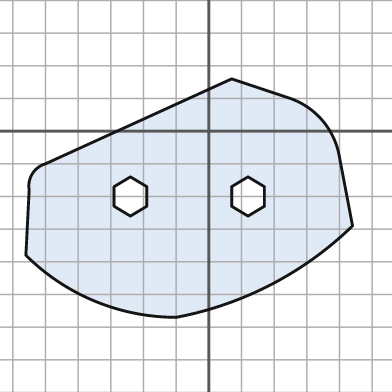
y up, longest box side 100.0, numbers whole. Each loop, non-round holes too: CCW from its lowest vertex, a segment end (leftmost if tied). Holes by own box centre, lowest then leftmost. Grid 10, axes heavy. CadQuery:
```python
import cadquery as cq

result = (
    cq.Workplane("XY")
    .moveTo(-10.0, -57.0)
    .threePointArc((19.0, -47.0), (44.0, -29.0))
    .lineTo(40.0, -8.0)
    .threePointArc((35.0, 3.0), (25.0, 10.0))
    .lineTo(7.0, 16.0)
    .lineTo(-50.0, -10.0)
    .threePointArc((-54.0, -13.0), (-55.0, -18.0))
    .lineTo(-56.0, -38.0)
    .threePointArc((-35.0, -52.0), (-10.0, -57.0))
    .close()
    .moveTo(-24.0, -26.0)
    .lineTo(-19.0, -23.0)
    .lineTo(-19.0, -17.0)
    .lineTo(-24.0, -14.0)
    .lineTo(-29.0, -17.0)
    .lineTo(-29.0, -23.0)
    .close()
    .moveTo(12.0, -26.0)
    .lineTo(17.0, -23.0)
    .lineTo(17.0, -17.0)
    .lineTo(12.0, -14.0)
    .lineTo(7.0, -17.0)
    .lineTo(7.0, -23.0)
    .close()
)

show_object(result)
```